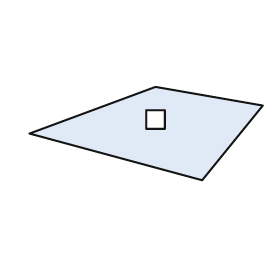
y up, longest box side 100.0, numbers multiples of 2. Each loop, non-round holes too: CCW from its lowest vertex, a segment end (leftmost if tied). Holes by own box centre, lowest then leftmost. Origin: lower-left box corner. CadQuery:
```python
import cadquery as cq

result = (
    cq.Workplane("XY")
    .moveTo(74.0, 0.0)
    .lineTo(100.0, 32.0)
    .lineTo(54.0, 40.0)
    .lineTo(0.0, 20.0)
    .close()
    .moveTo(50.0, 22.0)
    .lineTo(58.0, 22.0)
    .lineTo(58.0, 30.0)
    .lineTo(50.0, 30.0)
    .close()
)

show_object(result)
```